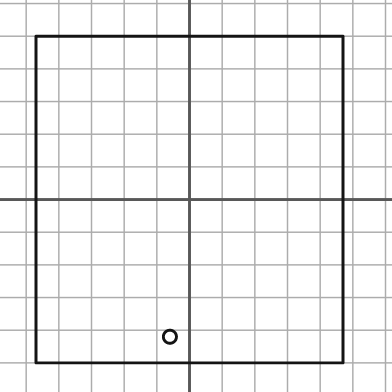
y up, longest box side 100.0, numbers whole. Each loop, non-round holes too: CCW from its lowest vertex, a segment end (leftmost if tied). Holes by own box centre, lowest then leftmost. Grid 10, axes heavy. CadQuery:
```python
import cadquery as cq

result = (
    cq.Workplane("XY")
    .moveTo(-47.0, -50.0)
    .lineTo(47.0, -50.0)
    .lineTo(47.0, 50.0)
    .lineTo(-47.0, 50.0)
    .close()
    .moveTo(-6.0, -42.0)
    .circle(2.0)
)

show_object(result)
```